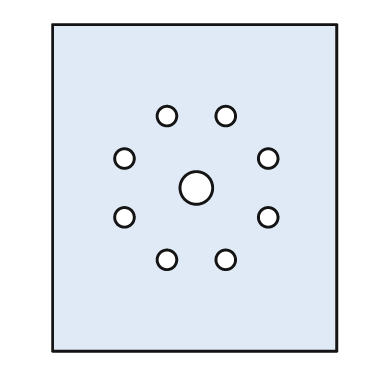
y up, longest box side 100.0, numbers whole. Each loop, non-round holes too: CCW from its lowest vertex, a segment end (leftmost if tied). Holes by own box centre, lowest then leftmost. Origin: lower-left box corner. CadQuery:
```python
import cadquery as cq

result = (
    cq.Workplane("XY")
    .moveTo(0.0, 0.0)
    .lineTo(87.0, 0.0)
    .lineTo(87.0, 100.0)
    .lineTo(0.0, 100.0)
    .close()
    .moveTo(35.0, 28.0)
    .circle(3.0)
    .moveTo(53.0, 28.0)
    .circle(3.0)
    .moveTo(22.0, 41.0)
    .circle(3.0)
    .moveTo(66.0, 41.0)
    .circle(3.0)
    .moveTo(44.0, 50.0)
    .circle(5.0)
    .moveTo(22.0, 59.0)
    .circle(3.0)
    .moveTo(66.0, 59.0)
    .circle(3.0)
    .moveTo(35.0, 72.0)
    .circle(3.0)
    .moveTo(53.0, 72.0)
    .circle(3.0)
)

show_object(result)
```